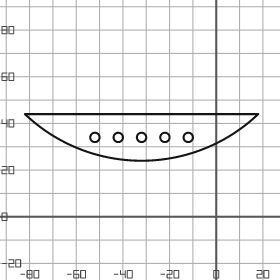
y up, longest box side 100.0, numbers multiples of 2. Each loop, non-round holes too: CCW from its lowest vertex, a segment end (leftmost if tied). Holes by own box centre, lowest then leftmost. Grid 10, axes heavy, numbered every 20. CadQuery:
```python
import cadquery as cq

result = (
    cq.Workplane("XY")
    .moveTo(-82.0, 44.0)
    .threePointArc((-32.0, 24.0), (18.0, 44.0))
    .close()
    .moveTo(-52.0, 34.0)
    .circle(2.0)
    .moveTo(-42.0, 34.0)
    .circle(2.0)
    .moveTo(-32.0, 34.0)
    .circle(2.0)
    .moveTo(-22.0, 34.0)
    .circle(2.0)
    .moveTo(-12.0, 34.0)
    .circle(2.0)
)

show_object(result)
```